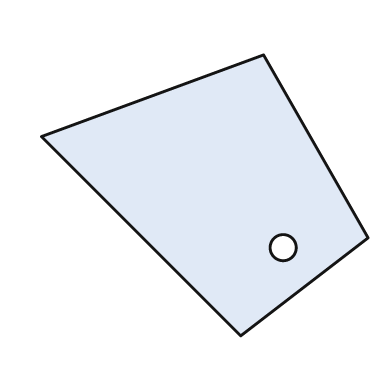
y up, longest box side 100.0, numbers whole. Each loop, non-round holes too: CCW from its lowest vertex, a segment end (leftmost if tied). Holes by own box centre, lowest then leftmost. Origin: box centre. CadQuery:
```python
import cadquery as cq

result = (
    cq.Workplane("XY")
    .moveTo(11.0, -43.0)
    .lineTo(50.0, -13.0)
    .lineTo(18.0, 43.0)
    .lineTo(-50.0, 18.0)
    .close()
    .moveTo(24.0, -16.0)
    .circle(4.0)
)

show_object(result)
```